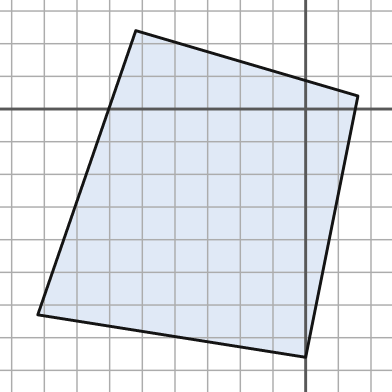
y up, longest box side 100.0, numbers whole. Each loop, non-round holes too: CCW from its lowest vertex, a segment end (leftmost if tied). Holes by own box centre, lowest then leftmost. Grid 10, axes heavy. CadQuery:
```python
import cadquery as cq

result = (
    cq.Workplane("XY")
    .moveTo(0.0, -76.0)
    .lineTo(16.0, 4.0)
    .lineTo(-52.0, 24.0)
    .lineTo(-82.0, -63.0)
    .close()
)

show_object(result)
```